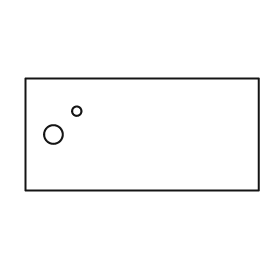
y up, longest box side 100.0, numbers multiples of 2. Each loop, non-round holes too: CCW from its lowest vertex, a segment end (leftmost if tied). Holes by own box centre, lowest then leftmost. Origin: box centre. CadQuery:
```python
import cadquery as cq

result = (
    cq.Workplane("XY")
    .moveTo(-50.0, -24.0)
    .lineTo(50.0, -24.0)
    .lineTo(50.0, 24.0)
    .lineTo(-50.0, 24.0)
    .close()
    .moveTo(-38.0, 0.0)
    .circle(4.0)
    .moveTo(-28.0, 10.0)
    .circle(2.0)
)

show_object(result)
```